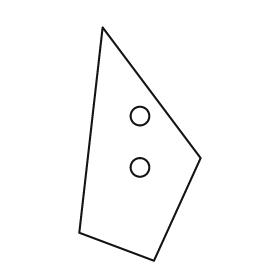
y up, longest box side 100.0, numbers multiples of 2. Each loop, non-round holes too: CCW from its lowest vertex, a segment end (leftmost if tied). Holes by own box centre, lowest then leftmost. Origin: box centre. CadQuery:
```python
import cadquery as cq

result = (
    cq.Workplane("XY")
    .moveTo(6.0, -50.0)
    .lineTo(26.0, -6.0)
    .lineTo(-16.0, 50.0)
    .lineTo(-26.0, -38.0)
    .close()
    .moveTo(0.0, -10.0)
    .circle(4.0)
    .moveTo(0.0, 12.0)
    .circle(4.0)
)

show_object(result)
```